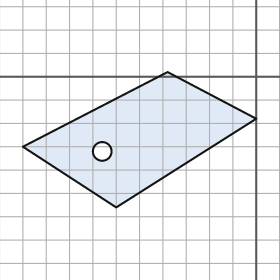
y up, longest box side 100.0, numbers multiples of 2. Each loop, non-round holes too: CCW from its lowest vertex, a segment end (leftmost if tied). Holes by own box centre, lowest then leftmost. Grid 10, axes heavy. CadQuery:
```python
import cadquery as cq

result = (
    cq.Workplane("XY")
    .moveTo(-60.0, -56.0)
    .lineTo(0.0, -18.0)
    .lineTo(-38.0, 2.0)
    .lineTo(-100.0, -30.0)
    .close()
    .moveTo(-66.0, -32.0)
    .circle(4.0)
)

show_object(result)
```